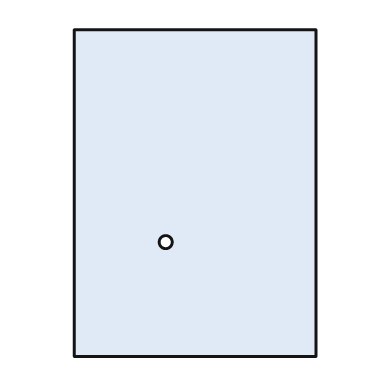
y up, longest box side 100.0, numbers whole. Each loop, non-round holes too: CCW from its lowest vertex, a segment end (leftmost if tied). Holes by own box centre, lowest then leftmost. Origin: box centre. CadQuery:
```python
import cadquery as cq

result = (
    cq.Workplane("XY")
    .moveTo(-37.0, -50.0)
    .lineTo(37.0, -50.0)
    .lineTo(37.0, 50.0)
    .lineTo(-37.0, 50.0)
    .close()
    .moveTo(-9.0, -15.0)
    .circle(2.0)
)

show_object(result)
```